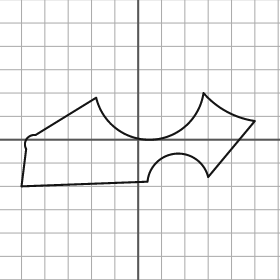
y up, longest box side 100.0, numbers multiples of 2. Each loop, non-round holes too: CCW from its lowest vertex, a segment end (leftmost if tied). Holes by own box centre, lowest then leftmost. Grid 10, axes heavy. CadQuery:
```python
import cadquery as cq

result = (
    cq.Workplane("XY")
    .moveTo(-50.0, -20.0)
    .lineTo(4.0, -18.0)
    .threePointArc((16.0, -6.0), (30.0, -16.0))
    .lineTo(50.0, 8.0)
    .threePointArc((38.0, 12.0), (28.0, 20.0))
    .threePointArc((6.0, 0.0), (-18.0, 18.0))
    .lineTo(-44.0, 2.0)
    .threePointArc((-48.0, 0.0), (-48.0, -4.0))
    .close()
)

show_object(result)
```